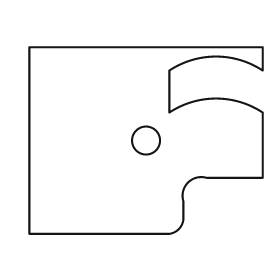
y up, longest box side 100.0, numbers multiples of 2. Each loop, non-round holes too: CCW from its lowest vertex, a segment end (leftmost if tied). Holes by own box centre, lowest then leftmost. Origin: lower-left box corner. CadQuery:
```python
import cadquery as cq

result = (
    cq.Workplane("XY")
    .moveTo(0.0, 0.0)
    .lineTo(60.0, 0.0)
    .threePointArc((64.0, 2.0), (66.0, 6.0))
    .lineTo(66.0, 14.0)
    .threePointArc((68.0, 22.0), (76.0, 24.0))
    .lineTo(100.0, 24.0)
    .lineTo(100.0, 52.0)
    .threePointArc((80.0, 58.0), (60.0, 52.0))
    .lineTo(60.0, 70.0)
    .threePointArc((80.0, 76.0), (100.0, 70.0))
    .lineTo(100.0, 80.0)
    .lineTo(0.0, 80.0)
    .close()
    .moveTo(50.0, 40.0)
    .circle(6.0)
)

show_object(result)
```